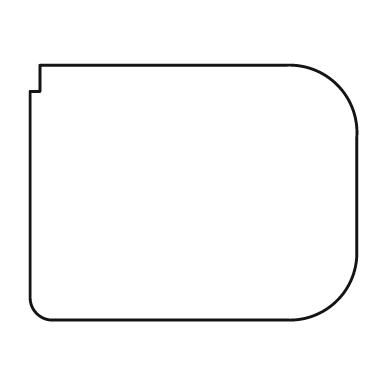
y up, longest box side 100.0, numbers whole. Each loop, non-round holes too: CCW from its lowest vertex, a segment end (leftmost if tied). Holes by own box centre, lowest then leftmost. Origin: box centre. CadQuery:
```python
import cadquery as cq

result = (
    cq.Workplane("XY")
    .moveTo(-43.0, -39.0)
    .lineTo(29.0, -39.0)
    .threePointArc((44.0, -33.0), (50.0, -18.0))
    .lineTo(50.0, 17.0)
    .threePointArc((44.0, 33.0), (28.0, 39.0))
    .lineTo(-47.0, 39.0)
    .lineTo(-47.0, 31.0)
    .lineTo(-50.0, 31.0)
    .lineTo(-50.0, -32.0)
    .threePointArc((-48.0, -37.0), (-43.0, -39.0))
    .close()
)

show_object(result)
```